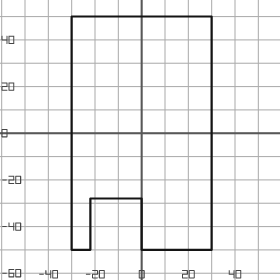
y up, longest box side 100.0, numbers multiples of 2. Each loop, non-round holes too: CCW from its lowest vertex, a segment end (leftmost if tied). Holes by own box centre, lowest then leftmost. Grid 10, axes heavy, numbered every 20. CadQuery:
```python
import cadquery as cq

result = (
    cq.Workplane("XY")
    .moveTo(-30.0, -50.0)
    .lineTo(-22.0, -50.0)
    .lineTo(-22.0, -28.0)
    .lineTo(0.0, -28.0)
    .lineTo(0.0, -50.0)
    .lineTo(30.0, -50.0)
    .lineTo(30.0, 50.0)
    .lineTo(-30.0, 50.0)
    .close()
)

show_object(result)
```